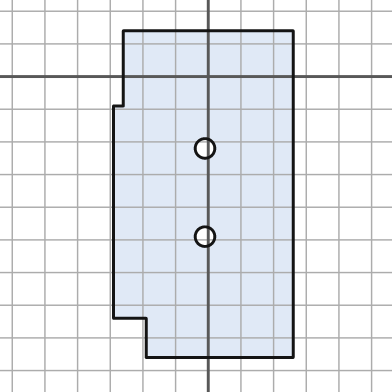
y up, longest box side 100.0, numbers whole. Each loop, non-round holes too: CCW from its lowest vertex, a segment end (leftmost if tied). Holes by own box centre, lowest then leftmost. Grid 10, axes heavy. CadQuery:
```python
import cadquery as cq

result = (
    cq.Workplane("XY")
    .moveTo(-19.0, -86.0)
    .lineTo(26.0, -86.0)
    .lineTo(26.0, 14.0)
    .lineTo(-26.0, 14.0)
    .lineTo(-26.0, -9.0)
    .lineTo(-29.0, -9.0)
    .lineTo(-29.0, -74.0)
    .lineTo(-19.0, -74.0)
    .close()
    .moveTo(-1.0, -49.0)
    .circle(3.0)
    .moveTo(-1.0, -22.0)
    .circle(3.0)
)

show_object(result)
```